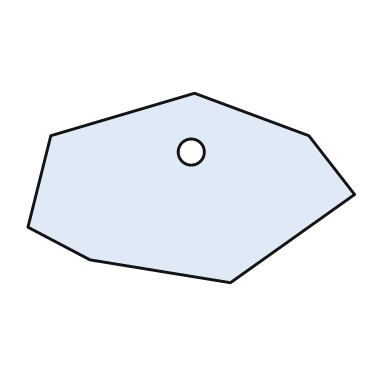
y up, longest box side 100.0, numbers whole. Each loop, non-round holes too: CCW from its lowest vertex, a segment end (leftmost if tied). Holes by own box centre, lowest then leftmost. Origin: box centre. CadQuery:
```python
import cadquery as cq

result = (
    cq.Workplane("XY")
    .moveTo(12.0, -29.0)
    .lineTo(50.0, -2.0)
    .lineTo(36.0, 16.0)
    .lineTo(1.0, 29.0)
    .lineTo(-43.0, 16.0)
    .lineTo(-50.0, -12.0)
    .lineTo(-31.0, -22.0)
    .close()
    .moveTo(0.0, 11.0)
    .circle(4.0)
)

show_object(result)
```